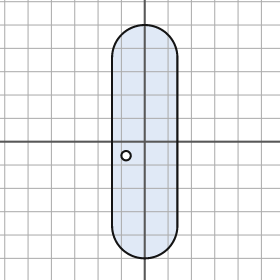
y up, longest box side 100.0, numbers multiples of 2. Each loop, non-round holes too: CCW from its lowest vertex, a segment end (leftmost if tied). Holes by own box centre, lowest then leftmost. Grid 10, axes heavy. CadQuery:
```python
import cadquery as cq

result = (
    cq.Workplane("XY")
    .moveTo(-14.0, -36.0)
    .threePointArc((0.0, -50.0), (14.0, -36.0))
    .lineTo(14.0, 36.0)
    .threePointArc((0.0, 50.0), (-14.0, 36.0))
    .close()
    .moveTo(-8.0, -6.0)
    .circle(2.0)
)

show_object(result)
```